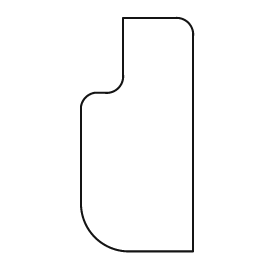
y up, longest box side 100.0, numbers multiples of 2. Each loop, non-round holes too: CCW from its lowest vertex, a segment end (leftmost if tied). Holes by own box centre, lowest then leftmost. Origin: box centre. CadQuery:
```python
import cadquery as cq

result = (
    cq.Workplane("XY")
    .moveTo(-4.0, -50.0)
    .lineTo(24.0, -50.0)
    .lineTo(24.0, 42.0)
    .threePointArc((22.0, 48.0), (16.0, 50.0))
    .lineTo(-6.0, 50.0)
    .lineTo(-6.0, 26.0)
    .threePointArc((-8.0, 20.0), (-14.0, 18.0))
    .lineTo(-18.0, 18.0)
    .threePointArc((-22.0, 16.0), (-24.0, 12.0))
    .lineTo(-24.0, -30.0)
    .threePointArc((-18.0, -44.0), (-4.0, -50.0))
    .close()
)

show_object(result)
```